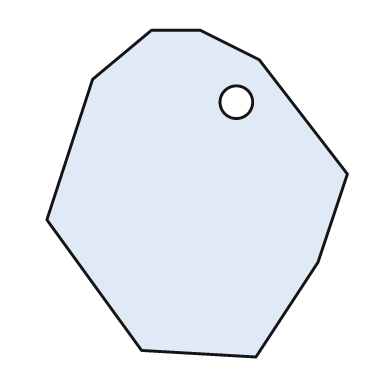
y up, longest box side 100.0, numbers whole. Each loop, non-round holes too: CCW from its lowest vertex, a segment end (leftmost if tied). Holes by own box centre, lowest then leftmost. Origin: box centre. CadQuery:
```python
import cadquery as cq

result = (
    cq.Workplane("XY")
    .moveTo(18.0, -50.0)
    .lineTo(37.0, -21.0)
    .lineTo(46.0, 6.0)
    .lineTo(19.0, 41.0)
    .lineTo(1.0, 50.0)
    .lineTo(-14.0, 50.0)
    .lineTo(-32.0, 35.0)
    .lineTo(-46.0, -8.0)
    .lineTo(-17.0, -48.0)
    .close()
    .moveTo(12.0, 28.0)
    .circle(5.0)
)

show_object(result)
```